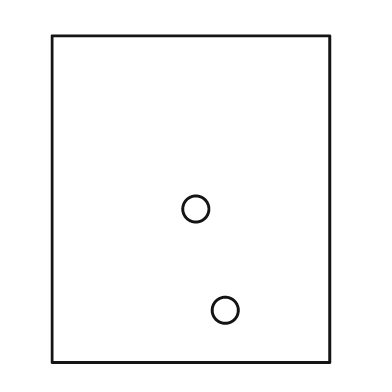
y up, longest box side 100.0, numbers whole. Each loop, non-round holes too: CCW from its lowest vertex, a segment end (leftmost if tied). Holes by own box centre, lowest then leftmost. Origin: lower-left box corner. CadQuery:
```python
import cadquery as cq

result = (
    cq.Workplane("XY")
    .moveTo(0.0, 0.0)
    .lineTo(85.0, 0.0)
    .lineTo(85.0, 100.0)
    .lineTo(0.0, 100.0)
    .close()
    .moveTo(53.0, 16.0)
    .circle(4.0)
    .moveTo(44.0, 47.0)
    .circle(4.0)
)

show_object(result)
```